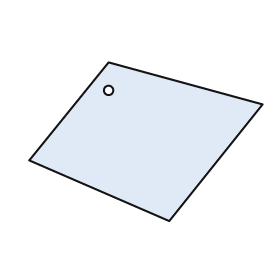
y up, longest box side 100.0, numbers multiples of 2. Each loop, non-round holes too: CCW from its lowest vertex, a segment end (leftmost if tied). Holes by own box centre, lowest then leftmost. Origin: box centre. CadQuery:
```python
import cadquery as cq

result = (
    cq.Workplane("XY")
    .moveTo(10.0, -34.0)
    .lineTo(50.0, 16.0)
    .lineTo(-16.0, 34.0)
    .lineTo(-50.0, -8.0)
    .close()
    .moveTo(-16.0, 22.0)
    .circle(2.0)
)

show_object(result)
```